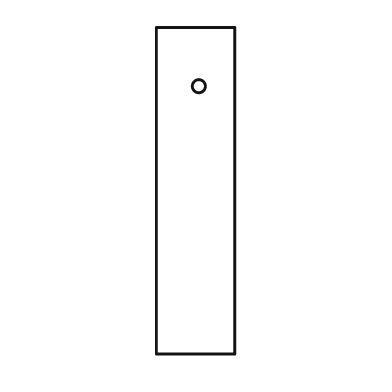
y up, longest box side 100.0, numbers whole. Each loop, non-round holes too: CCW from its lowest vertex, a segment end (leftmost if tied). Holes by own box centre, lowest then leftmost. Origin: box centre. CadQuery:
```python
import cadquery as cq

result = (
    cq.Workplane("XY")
    .moveTo(-12.0, -50.0)
    .lineTo(12.0, -50.0)
    .lineTo(12.0, 50.0)
    .lineTo(-12.0, 50.0)
    .close()
    .moveTo(1.0, 32.0)
    .circle(2.0)
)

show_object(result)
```